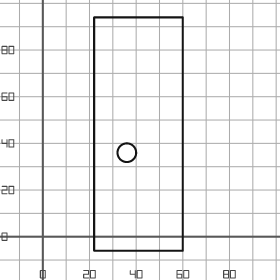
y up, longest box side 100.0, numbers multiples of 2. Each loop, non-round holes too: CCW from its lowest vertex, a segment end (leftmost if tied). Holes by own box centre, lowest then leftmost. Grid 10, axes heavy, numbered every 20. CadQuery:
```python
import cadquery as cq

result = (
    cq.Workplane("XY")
    .moveTo(22.0, -6.0)
    .lineTo(60.0, -6.0)
    .lineTo(60.0, 94.0)
    .lineTo(22.0, 94.0)
    .close()
    .moveTo(36.0, 36.0)
    .circle(4.0)
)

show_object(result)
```